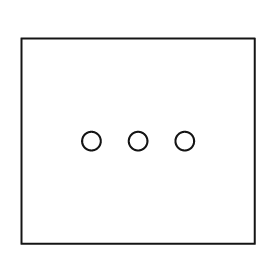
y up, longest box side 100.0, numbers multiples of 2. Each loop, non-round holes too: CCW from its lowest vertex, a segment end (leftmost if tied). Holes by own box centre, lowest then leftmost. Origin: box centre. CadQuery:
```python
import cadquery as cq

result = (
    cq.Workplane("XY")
    .moveTo(-50.0, -44.0)
    .lineTo(50.0, -44.0)
    .lineTo(50.0, 44.0)
    .lineTo(-50.0, 44.0)
    .close()
    .moveTo(-20.0, 0.0)
    .circle(4.0)
    .moveTo(0.0, 0.0)
    .circle(4.0)
    .moveTo(20.0, 0.0)
    .circle(4.0)
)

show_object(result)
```